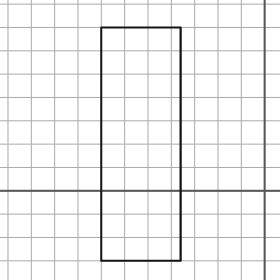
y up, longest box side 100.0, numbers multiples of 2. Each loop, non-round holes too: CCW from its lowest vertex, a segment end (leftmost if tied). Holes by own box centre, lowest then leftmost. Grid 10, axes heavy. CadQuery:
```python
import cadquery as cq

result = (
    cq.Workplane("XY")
    .moveTo(-70.0, -30.0)
    .lineTo(-36.0, -30.0)
    .lineTo(-36.0, 70.0)
    .lineTo(-70.0, 70.0)
    .close()
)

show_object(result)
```